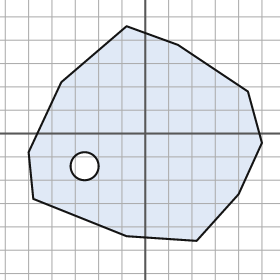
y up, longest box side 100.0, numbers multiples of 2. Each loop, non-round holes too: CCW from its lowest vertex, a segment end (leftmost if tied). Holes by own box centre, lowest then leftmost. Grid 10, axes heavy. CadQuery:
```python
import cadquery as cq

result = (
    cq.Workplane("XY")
    .moveTo(22.0, -46.0)
    .lineTo(40.0, -26.0)
    .lineTo(50.0, -4.0)
    .lineTo(44.0, 18.0)
    .lineTo(14.0, 38.0)
    .lineTo(-8.0, 46.0)
    .lineTo(-36.0, 22.0)
    .lineTo(-50.0, -8.0)
    .lineTo(-48.0, -28.0)
    .lineTo(-8.0, -44.0)
    .close()
    .moveTo(-26.0, -14.0)
    .circle(6.0)
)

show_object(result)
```